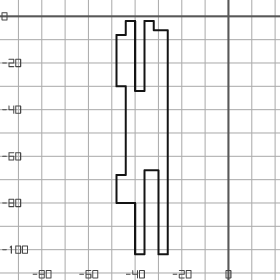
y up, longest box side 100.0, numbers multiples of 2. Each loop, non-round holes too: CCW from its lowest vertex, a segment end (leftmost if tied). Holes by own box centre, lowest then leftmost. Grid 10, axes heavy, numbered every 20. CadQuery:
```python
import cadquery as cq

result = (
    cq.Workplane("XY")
    .moveTo(-40.0, -102.0)
    .lineTo(-36.0, -102.0)
    .lineTo(-36.0, -66.0)
    .lineTo(-30.0, -66.0)
    .lineTo(-30.0, -102.0)
    .lineTo(-26.0, -102.0)
    .lineTo(-26.0, -6.0)
    .lineTo(-32.0, -6.0)
    .lineTo(-32.0, -2.0)
    .lineTo(-36.0, -2.0)
    .lineTo(-36.0, -32.0)
    .lineTo(-40.0, -32.0)
    .lineTo(-40.0, -2.0)
    .lineTo(-44.0, -2.0)
    .lineTo(-44.0, -8.0)
    .lineTo(-48.0, -8.0)
    .lineTo(-48.0, -30.0)
    .lineTo(-44.0, -30.0)
    .lineTo(-44.0, -68.0)
    .lineTo(-48.0, -68.0)
    .lineTo(-48.0, -80.0)
    .lineTo(-40.0, -80.0)
    .close()
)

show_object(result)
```